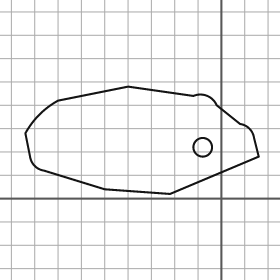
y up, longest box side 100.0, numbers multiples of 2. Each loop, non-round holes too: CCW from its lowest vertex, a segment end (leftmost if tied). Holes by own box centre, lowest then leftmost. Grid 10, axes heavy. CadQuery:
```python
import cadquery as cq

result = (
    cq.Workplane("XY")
    .moveTo(-22.0, 2.0)
    .lineTo(16.0, 18.0)
    .lineTo(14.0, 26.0)
    .threePointArc((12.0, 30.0), (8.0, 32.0))
    .lineTo(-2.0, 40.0)
    .threePointArc((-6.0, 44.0), (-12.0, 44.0))
    .lineTo(-40.0, 48.0)
    .lineTo(-70.0, 42.0)
    .threePointArc((-78.0, 36.0), (-84.0, 28.0))
    .lineTo(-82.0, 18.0)
    .threePointArc((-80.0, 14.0), (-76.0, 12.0))
    .lineTo(-50.0, 4.0)
    .close()
    .moveTo(-8.0, 22.0)
    .circle(4.0)
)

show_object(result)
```